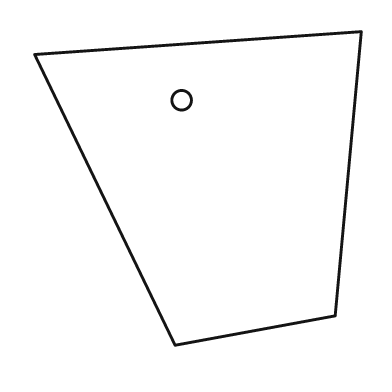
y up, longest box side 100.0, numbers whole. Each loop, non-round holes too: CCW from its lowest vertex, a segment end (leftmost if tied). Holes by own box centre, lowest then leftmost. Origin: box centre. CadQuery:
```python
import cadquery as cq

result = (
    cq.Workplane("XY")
    .moveTo(-7.0, -48.0)
    .lineTo(42.0, -39.0)
    .lineTo(50.0, 48.0)
    .lineTo(-50.0, 41.0)
    .close()
    .moveTo(-5.0, 27.0)
    .circle(3.0)
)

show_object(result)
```